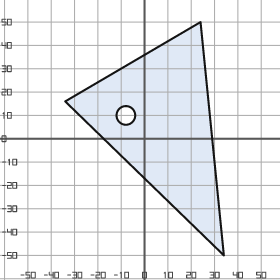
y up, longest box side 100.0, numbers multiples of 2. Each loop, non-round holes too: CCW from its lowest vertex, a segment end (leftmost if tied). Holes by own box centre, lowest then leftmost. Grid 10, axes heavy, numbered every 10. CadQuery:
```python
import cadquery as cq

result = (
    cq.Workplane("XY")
    .moveTo(34.0, -50.0)
    .lineTo(24.0, 50.0)
    .lineTo(-34.0, 16.0)
    .close()
    .moveTo(-8.0, 10.0)
    .circle(4.0)
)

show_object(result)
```